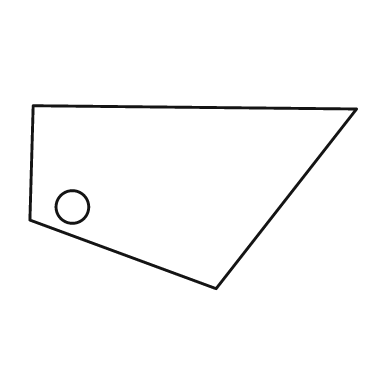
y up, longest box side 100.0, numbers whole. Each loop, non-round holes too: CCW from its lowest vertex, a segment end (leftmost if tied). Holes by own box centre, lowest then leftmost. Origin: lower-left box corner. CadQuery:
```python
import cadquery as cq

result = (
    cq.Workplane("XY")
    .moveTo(57.0, 0.0)
    .lineTo(100.0, 55.0)
    .lineTo(1.0, 56.0)
    .lineTo(0.0, 21.0)
    .close()
    .moveTo(13.0, 25.0)
    .circle(5.0)
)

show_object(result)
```